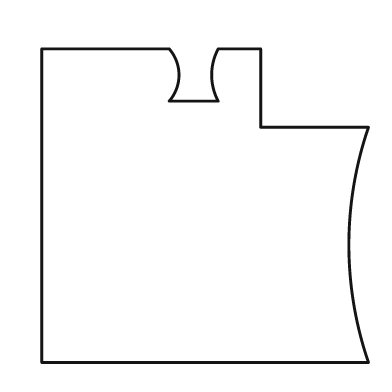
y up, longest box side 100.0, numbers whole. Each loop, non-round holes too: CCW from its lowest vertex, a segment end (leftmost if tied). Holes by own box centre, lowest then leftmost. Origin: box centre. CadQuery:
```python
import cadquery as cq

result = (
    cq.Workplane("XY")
    .moveTo(-50.0, -48.0)
    .lineTo(50.0, -48.0)
    .threePointArc((44.0, -12.0), (50.0, 24.0))
    .lineTo(17.0, 24.0)
    .lineTo(17.0, 48.0)
    .lineTo(4.0, 48.0)
    .threePointArc((2.0, 40.0), (4.0, 32.0))
    .lineTo(-11.0, 32.0)
    .threePointArc((-8.0, 40.0), (-11.0, 48.0))
    .lineTo(-50.0, 48.0)
    .close()
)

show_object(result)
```